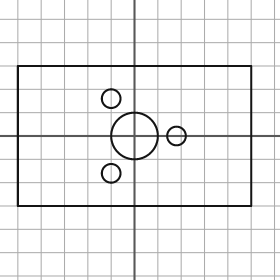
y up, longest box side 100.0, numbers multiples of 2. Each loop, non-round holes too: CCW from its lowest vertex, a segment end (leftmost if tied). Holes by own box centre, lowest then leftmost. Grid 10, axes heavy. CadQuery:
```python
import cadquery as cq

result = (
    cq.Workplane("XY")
    .moveTo(-50.0, -30.0)
    .lineTo(50.0, -30.0)
    .lineTo(50.0, 30.0)
    .lineTo(-50.0, 30.0)
    .close()
    .moveTo(-10.0, -16.0)
    .circle(4.0)
    .moveTo(0.0, 0.0)
    .circle(10.0)
    .moveTo(18.0, 0.0)
    .circle(4.0)
    .moveTo(-10.0, 16.0)
    .circle(4.0)
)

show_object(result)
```